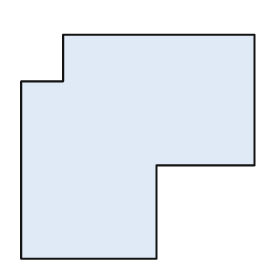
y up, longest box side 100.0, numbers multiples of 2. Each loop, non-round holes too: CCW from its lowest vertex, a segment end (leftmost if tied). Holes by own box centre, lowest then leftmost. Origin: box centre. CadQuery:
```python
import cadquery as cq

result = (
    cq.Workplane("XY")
    .moveTo(-50.0, -48.0)
    .lineTo(8.0, -48.0)
    .lineTo(8.0, -8.0)
    .lineTo(50.0, -8.0)
    .lineTo(50.0, 48.0)
    .lineTo(-32.0, 48.0)
    .lineTo(-32.0, 28.0)
    .lineTo(-50.0, 28.0)
    .close()
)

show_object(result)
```